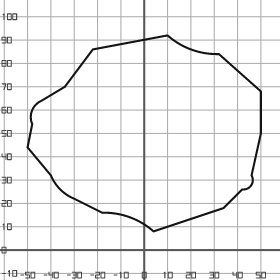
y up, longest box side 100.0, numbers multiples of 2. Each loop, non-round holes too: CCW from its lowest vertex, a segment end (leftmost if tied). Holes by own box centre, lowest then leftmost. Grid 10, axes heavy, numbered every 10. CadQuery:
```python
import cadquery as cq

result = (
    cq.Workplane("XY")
    .moveTo(4.0, 8.0)
    .lineTo(34.0, 18.0)
    .lineTo(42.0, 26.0)
    .threePointArc((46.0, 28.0), (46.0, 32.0))
    .lineTo(50.0, 50.0)
    .lineTo(50.0, 68.0)
    .lineTo(32.0, 84.0)
    .threePointArc((20.0, 86.0), (10.0, 92.0))
    .lineTo(-22.0, 86.0)
    .lineTo(-34.0, 70.0)
    .lineTo(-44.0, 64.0)
    .threePointArc((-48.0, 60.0), (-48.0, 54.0))
    .lineTo(-50.0, 44.0)
    .lineTo(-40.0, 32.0)
    .threePointArc((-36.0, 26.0), (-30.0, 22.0))
    .lineTo(-18.0, 16.0)
    .threePointArc((-6.0, 14.0), (4.0, 8.0))
    .close()
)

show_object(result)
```